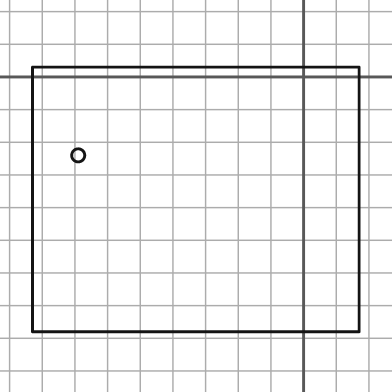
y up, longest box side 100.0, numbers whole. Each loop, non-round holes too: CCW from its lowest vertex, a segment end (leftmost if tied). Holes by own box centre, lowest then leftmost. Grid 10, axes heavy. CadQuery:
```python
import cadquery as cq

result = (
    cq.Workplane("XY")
    .moveTo(-83.0, -78.0)
    .lineTo(17.0, -78.0)
    .lineTo(17.0, 3.0)
    .lineTo(-83.0, 3.0)
    .close()
    .moveTo(-69.0, -24.0)
    .circle(2.0)
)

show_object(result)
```